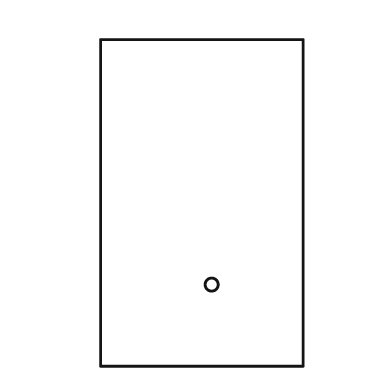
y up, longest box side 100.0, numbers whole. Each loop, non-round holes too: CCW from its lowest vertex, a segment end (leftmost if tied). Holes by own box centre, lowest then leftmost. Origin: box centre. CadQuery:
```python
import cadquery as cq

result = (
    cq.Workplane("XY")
    .moveTo(-31.0, -50.0)
    .lineTo(31.0, -50.0)
    .lineTo(31.0, 50.0)
    .lineTo(-31.0, 50.0)
    .close()
    .moveTo(3.0, -25.0)
    .circle(2.0)
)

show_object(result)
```